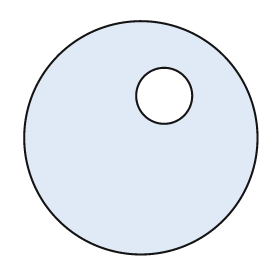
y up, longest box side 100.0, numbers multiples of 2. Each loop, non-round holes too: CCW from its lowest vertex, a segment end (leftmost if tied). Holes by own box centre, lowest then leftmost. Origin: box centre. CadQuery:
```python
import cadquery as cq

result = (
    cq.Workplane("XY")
    .moveTo(0.0, 0.0)
    .circle(50.0)
    .moveTo(10.0, 18.0)
    .circle(12.0)
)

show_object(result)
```